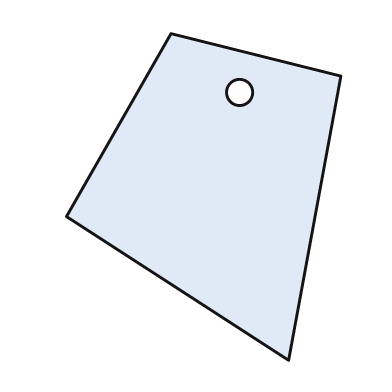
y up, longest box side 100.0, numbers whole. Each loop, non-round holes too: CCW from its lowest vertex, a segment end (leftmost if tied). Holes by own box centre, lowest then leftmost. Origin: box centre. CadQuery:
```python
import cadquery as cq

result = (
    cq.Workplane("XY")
    .moveTo(26.0, -50.0)
    .lineTo(42.0, 37.0)
    .lineTo(-10.0, 50.0)
    .lineTo(-42.0, -6.0)
    .close()
    .moveTo(11.0, 32.0)
    .circle(4.0)
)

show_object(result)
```